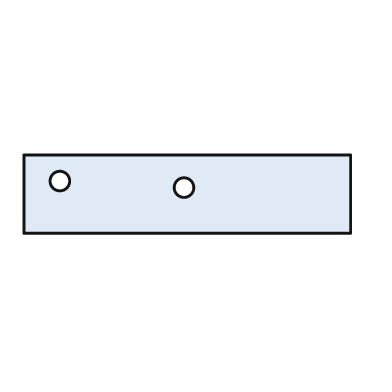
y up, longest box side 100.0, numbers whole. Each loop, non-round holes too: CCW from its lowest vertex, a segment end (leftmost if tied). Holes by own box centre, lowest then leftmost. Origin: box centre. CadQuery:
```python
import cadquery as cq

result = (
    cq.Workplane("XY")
    .moveTo(-50.0, -12.0)
    .lineTo(50.0, -12.0)
    .lineTo(50.0, 12.0)
    .lineTo(-50.0, 12.0)
    .close()
    .moveTo(-1.0, 2.0)
    .circle(3.0)
    .moveTo(-39.0, 4.0)
    .circle(3.0)
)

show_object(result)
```